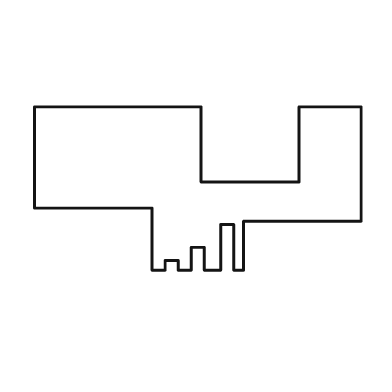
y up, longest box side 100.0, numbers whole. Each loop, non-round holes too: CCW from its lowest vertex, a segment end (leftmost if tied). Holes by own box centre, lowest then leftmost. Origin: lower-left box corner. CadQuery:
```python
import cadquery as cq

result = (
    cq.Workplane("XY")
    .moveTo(36.0, 0.0)
    .lineTo(40.0, 0.0)
    .lineTo(40.0, 3.0)
    .lineTo(44.0, 3.0)
    .lineTo(44.0, 0.0)
    .lineTo(48.0, 0.0)
    .lineTo(48.0, 7.0)
    .lineTo(52.0, 7.0)
    .lineTo(52.0, 0.0)
    .lineTo(57.0, 0.0)
    .lineTo(57.0, 14.0)
    .lineTo(61.0, 14.0)
    .lineTo(61.0, 0.0)
    .lineTo(64.0, 0.0)
    .lineTo(64.0, 15.0)
    .lineTo(100.0, 15.0)
    .lineTo(100.0, 50.0)
    .lineTo(81.0, 50.0)
    .lineTo(81.0, 27.0)
    .lineTo(51.0, 27.0)
    .lineTo(51.0, 50.0)
    .lineTo(0.0, 50.0)
    .lineTo(0.0, 19.0)
    .lineTo(36.0, 19.0)
    .close()
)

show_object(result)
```